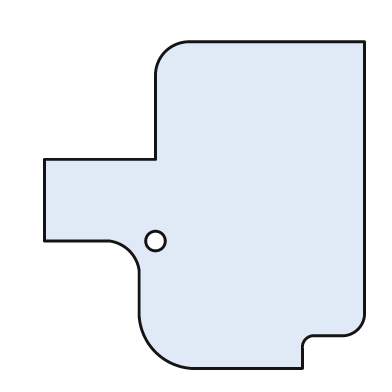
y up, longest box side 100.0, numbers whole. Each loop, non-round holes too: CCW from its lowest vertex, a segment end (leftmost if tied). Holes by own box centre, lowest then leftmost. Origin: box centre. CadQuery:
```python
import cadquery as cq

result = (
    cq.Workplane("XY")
    .moveTo(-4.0, -50.0)
    .lineTo(30.0, -50.0)
    .lineTo(30.0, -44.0)
    .threePointArc((31.0, -41.0), (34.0, -40.0))
    .lineTo(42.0, -40.0)
    .threePointArc((47.0, -38.0), (49.0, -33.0))
    .lineTo(49.0, 50.0)
    .lineTo(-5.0, 50.0)
    .threePointArc((-12.0, 47.0), (-15.0, 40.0))
    .lineTo(-15.0, 14.0)
    .lineTo(-49.0, 14.0)
    .lineTo(-49.0, -11.0)
    .lineTo(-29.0, -11.0)
    .threePointArc((-23.0, -14.0), (-20.0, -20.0))
    .lineTo(-20.0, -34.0)
    .threePointArc((-15.0, -45.0), (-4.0, -50.0))
    .close()
    .moveTo(-15.0, -11.0)
    .circle(3.0)
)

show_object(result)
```